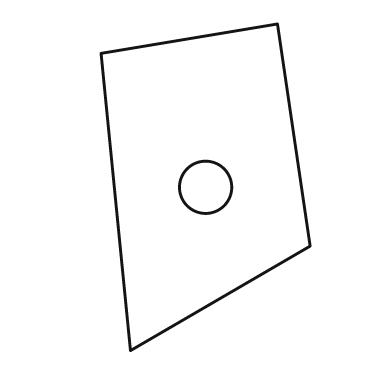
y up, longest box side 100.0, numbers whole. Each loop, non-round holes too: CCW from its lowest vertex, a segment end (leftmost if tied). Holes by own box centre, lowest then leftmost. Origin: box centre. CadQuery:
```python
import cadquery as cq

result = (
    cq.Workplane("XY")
    .moveTo(-23.0, -50.0)
    .lineTo(32.0, -18.0)
    .lineTo(22.0, 50.0)
    .lineTo(-32.0, 41.0)
    .close()
    .moveTo(0.0, 0.0)
    .circle(8.0)
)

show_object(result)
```